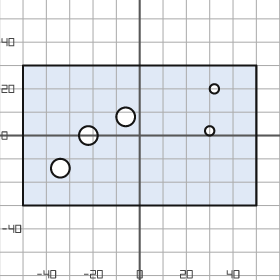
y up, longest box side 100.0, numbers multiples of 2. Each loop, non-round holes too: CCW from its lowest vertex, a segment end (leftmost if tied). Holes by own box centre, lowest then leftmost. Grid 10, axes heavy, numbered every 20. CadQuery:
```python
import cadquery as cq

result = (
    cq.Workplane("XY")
    .moveTo(-50.0, -30.0)
    .lineTo(50.0, -30.0)
    .lineTo(50.0, 30.0)
    .lineTo(-50.0, 30.0)
    .close()
    .moveTo(-34.0, -14.0)
    .circle(4.0)
    .moveTo(-22.0, 0.0)
    .circle(4.0)
    .moveTo(30.0, 2.0)
    .circle(2.0)
    .moveTo(-6.0, 8.0)
    .circle(4.0)
    .moveTo(32.0, 20.0)
    .circle(2.0)
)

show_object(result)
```